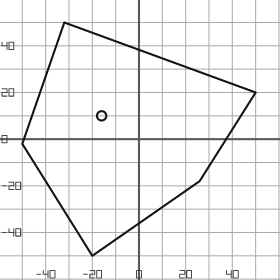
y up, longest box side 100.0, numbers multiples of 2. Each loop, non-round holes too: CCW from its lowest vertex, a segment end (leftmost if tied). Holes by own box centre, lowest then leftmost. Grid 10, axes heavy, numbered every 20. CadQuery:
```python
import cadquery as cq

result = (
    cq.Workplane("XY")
    .moveTo(-20.0, -50.0)
    .lineTo(26.0, -18.0)
    .lineTo(50.0, 20.0)
    .lineTo(-32.0, 50.0)
    .lineTo(-50.0, -2.0)
    .close()
    .moveTo(-16.0, 10.0)
    .circle(2.0)
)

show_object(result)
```